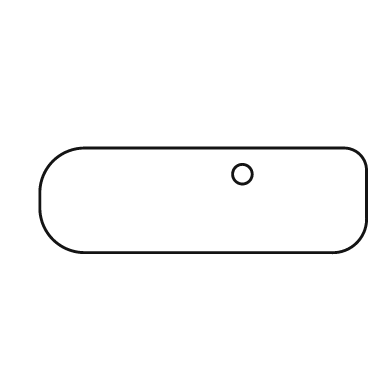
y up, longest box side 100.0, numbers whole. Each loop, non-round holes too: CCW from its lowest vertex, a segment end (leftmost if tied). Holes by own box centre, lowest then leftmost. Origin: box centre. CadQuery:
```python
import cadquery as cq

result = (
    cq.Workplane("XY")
    .moveTo(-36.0, -16.0)
    .lineTo(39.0, -16.0)
    .threePointArc((47.0, -13.0), (50.0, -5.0))
    .lineTo(50.0, 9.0)
    .threePointArc((48.0, 14.0), (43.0, 16.0))
    .lineTo(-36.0, 16.0)
    .threePointArc((-46.0, 12.0), (-50.0, 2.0))
    .lineTo(-50.0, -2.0)
    .threePointArc((-46.0, -12.0), (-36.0, -16.0))
    .close()
    .moveTo(12.0, 8.0)
    .circle(3.0)
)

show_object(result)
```